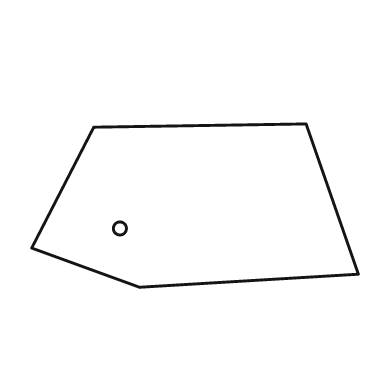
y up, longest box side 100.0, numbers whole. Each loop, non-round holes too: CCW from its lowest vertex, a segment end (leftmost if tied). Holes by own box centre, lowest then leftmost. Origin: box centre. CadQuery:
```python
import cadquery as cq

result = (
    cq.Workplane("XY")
    .moveTo(-17.0, -25.0)
    .lineTo(50.0, -21.0)
    .lineTo(34.0, 25.0)
    .lineTo(-31.0, 24.0)
    .lineTo(-50.0, -13.0)
    .close()
    .moveTo(-23.0, -7.0)
    .circle(2.0)
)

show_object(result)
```